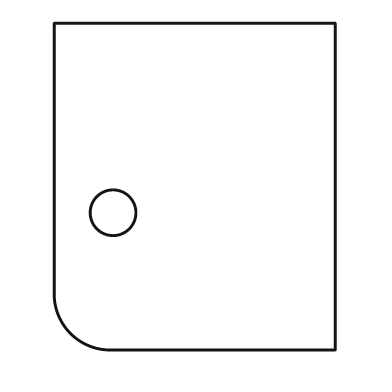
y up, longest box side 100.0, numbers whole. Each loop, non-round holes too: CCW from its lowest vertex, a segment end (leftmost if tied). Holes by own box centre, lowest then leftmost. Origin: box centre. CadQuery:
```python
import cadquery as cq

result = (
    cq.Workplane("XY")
    .moveTo(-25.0, -50.0)
    .lineTo(43.0, -50.0)
    .lineTo(43.0, 50.0)
    .lineTo(-43.0, 50.0)
    .lineTo(-43.0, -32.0)
    .threePointArc((-38.0, -45.0), (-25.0, -50.0))
    .close()
    .moveTo(-25.0, -8.0)
    .circle(7.0)
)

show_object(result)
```